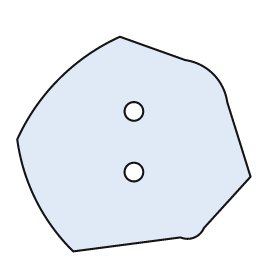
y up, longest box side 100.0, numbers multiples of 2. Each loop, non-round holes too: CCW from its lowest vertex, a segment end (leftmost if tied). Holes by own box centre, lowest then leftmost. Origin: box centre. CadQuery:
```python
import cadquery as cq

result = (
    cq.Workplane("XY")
    .moveTo(-26.0, -46.0)
    .lineTo(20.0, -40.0)
    .threePointArc((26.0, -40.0), (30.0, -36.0))
    .lineTo(50.0, -14.0)
    .lineTo(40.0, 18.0)
    .threePointArc((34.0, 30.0), (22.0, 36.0))
    .lineTo(-6.0, 46.0)
    .threePointArc((-32.0, 28.0), (-50.0, 2.0))
    .threePointArc((-42.0, -24.0), (-26.0, -46.0))
    .close()
    .moveTo(0.0, -12.0)
    .circle(4.0)
    .moveTo(0.0, 14.0)
    .circle(4.0)
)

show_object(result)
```